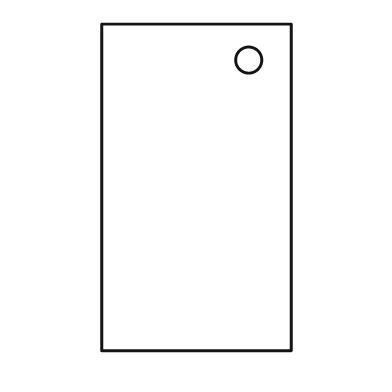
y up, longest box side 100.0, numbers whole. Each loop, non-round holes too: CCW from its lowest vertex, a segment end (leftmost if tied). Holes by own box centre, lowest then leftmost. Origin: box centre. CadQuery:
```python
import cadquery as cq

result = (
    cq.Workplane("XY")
    .moveTo(-29.0, -50.0)
    .lineTo(29.0, -50.0)
    .lineTo(29.0, 50.0)
    .lineTo(-29.0, 50.0)
    .close()
    .moveTo(16.0, 39.0)
    .circle(4.0)
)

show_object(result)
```